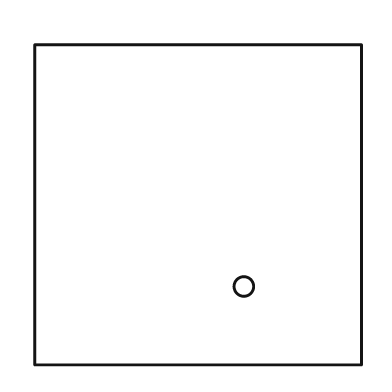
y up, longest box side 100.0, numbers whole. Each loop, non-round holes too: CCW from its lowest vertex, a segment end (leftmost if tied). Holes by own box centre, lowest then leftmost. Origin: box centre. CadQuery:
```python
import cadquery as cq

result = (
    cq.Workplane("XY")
    .moveTo(-50.0, -49.0)
    .lineTo(50.0, -49.0)
    .lineTo(50.0, 49.0)
    .lineTo(-50.0, 49.0)
    .close()
    .moveTo(14.0, -25.0)
    .circle(3.0)
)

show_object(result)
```